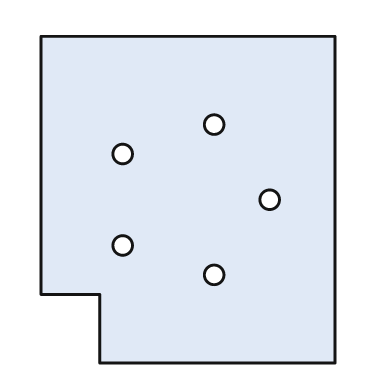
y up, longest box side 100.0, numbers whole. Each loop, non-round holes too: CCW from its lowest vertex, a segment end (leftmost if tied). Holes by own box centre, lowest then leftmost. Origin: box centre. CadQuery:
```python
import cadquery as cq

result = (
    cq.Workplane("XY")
    .moveTo(-27.0, -50.0)
    .lineTo(45.0, -50.0)
    .lineTo(45.0, 50.0)
    .lineTo(-45.0, 50.0)
    .lineTo(-45.0, -29.0)
    .lineTo(-27.0, -29.0)
    .close()
    .moveTo(8.0, -23.0)
    .circle(3.0)
    .moveTo(-20.0, -14.0)
    .circle(3.0)
    .moveTo(25.0, 0.0)
    .circle(3.0)
    .moveTo(-20.0, 14.0)
    .circle(3.0)
    .moveTo(8.0, 23.0)
    .circle(3.0)
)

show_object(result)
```